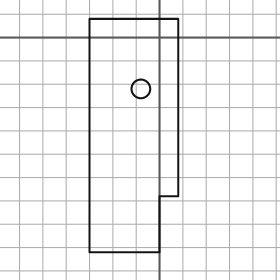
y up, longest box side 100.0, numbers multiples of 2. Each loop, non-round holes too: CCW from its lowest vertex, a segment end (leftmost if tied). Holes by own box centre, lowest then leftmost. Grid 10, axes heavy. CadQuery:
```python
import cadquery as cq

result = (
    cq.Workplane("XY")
    .moveTo(-30.0, -92.0)
    .lineTo(0.0, -92.0)
    .lineTo(0.0, -68.0)
    .lineTo(8.0, -68.0)
    .lineTo(8.0, 8.0)
    .lineTo(-30.0, 8.0)
    .close()
    .moveTo(-8.0, -22.0)
    .circle(4.0)
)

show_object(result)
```